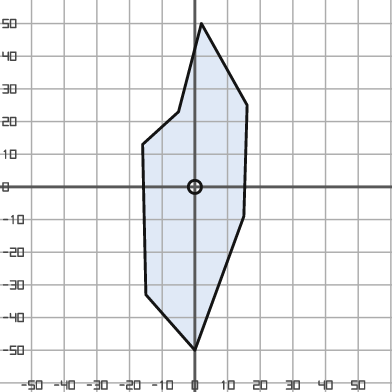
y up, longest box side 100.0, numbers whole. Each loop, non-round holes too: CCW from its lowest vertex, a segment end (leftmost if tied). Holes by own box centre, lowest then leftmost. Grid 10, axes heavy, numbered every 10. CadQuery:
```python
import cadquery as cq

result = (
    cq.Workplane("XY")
    .moveTo(0.0, -50.0)
    .lineTo(15.0, -9.0)
    .lineTo(16.0, 25.0)
    .lineTo(2.0, 50.0)
    .lineTo(-5.0, 23.0)
    .lineTo(-16.0, 13.0)
    .lineTo(-15.0, -33.0)
    .close()
    .moveTo(0.0, 0.0)
    .circle(2.0)
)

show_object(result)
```